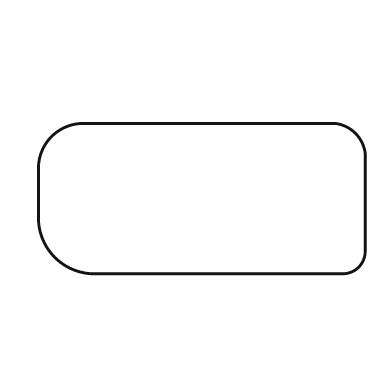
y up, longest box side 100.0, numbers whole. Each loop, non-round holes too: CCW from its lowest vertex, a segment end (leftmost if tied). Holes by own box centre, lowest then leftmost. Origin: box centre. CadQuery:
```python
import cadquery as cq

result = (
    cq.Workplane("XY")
    .moveTo(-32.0, -23.0)
    .lineTo(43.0, -23.0)
    .threePointArc((48.0, -21.0), (50.0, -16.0))
    .lineTo(50.0, 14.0)
    .threePointArc((47.0, 20.0), (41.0, 23.0))
    .lineTo(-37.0, 23.0)
    .threePointArc((-46.0, 19.0), (-50.0, 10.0))
    .lineTo(-50.0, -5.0)
    .threePointArc((-45.0, -18.0), (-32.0, -23.0))
    .close()
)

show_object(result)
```